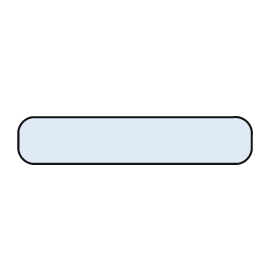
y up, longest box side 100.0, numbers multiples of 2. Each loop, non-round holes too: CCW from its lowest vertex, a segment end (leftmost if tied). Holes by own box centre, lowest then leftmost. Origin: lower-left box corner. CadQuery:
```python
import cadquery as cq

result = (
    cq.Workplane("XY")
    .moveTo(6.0, 0.0)
    .lineTo(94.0, 0.0)
    .threePointArc((98.0, 2.0), (100.0, 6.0))
    .lineTo(100.0, 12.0)
    .threePointArc((98.0, 18.0), (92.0, 20.0))
    .lineTo(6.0, 20.0)
    .threePointArc((2.0, 18.0), (0.0, 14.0))
    .lineTo(0.0, 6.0)
    .threePointArc((2.0, 2.0), (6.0, 0.0))
    .close()
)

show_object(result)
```